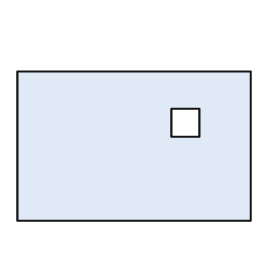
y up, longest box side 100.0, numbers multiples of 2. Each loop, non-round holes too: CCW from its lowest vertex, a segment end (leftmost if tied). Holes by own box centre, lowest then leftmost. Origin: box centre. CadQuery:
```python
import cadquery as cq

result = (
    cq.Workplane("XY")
    .moveTo(-50.0, -32.0)
    .lineTo(50.0, -32.0)
    .lineTo(50.0, 32.0)
    .lineTo(-50.0, 32.0)
    .close()
    .moveTo(16.0, 4.0)
    .lineTo(28.0, 4.0)
    .lineTo(28.0, 16.0)
    .lineTo(16.0, 16.0)
    .close()
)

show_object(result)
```